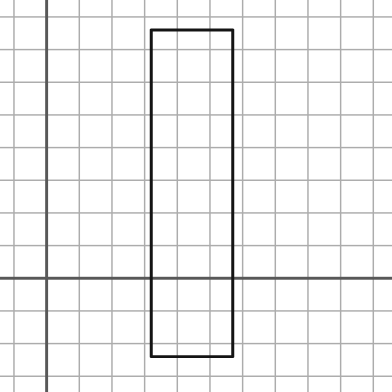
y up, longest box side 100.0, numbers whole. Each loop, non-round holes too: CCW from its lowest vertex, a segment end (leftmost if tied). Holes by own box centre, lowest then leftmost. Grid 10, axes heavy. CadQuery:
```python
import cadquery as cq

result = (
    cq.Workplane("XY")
    .moveTo(32.0, -24.0)
    .lineTo(57.0, -24.0)
    .lineTo(57.0, 76.0)
    .lineTo(32.0, 76.0)
    .close()
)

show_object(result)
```